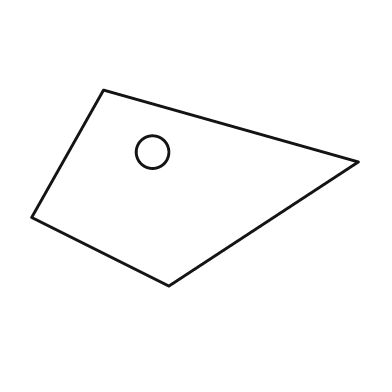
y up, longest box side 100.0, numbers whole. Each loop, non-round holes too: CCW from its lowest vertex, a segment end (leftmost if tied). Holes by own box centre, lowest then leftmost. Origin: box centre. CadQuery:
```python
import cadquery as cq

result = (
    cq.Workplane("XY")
    .moveTo(-8.0, -30.0)
    .lineTo(50.0, 8.0)
    .lineTo(-28.0, 30.0)
    .lineTo(-50.0, -9.0)
    .close()
    .moveTo(-13.0, 11.0)
    .circle(5.0)
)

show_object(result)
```